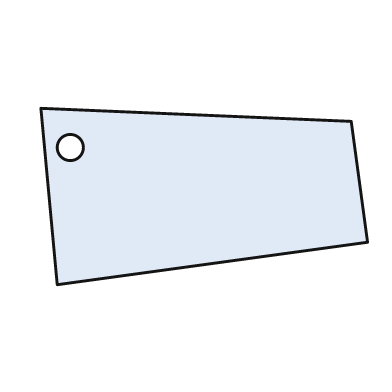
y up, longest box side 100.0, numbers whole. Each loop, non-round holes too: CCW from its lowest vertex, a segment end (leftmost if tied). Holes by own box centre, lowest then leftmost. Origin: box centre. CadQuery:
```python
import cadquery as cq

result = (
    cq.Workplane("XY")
    .moveTo(-45.0, -27.0)
    .lineTo(50.0, -14.0)
    .lineTo(45.0, 23.0)
    .lineTo(-50.0, 27.0)
    .close()
    .moveTo(-41.0, 15.0)
    .circle(4.0)
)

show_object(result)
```